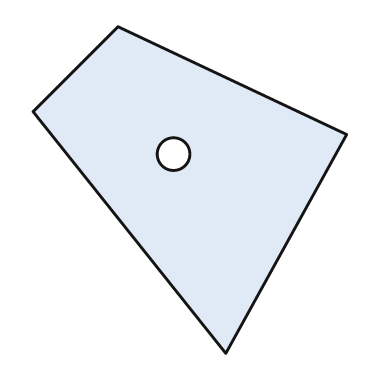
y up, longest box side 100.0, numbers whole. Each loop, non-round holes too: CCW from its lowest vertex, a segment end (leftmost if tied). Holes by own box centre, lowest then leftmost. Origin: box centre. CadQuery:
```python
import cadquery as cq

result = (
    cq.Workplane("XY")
    .moveTo(11.0, -50.0)
    .lineTo(48.0, 17.0)
    .lineTo(-22.0, 50.0)
    .lineTo(-48.0, 24.0)
    .close()
    .moveTo(-5.0, 11.0)
    .circle(5.0)
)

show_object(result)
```